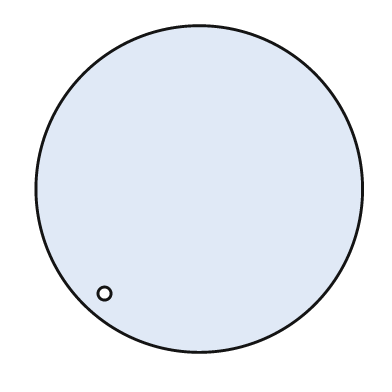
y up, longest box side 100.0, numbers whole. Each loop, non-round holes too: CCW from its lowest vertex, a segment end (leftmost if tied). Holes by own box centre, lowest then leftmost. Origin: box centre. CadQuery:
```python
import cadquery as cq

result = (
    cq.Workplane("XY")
    .moveTo(0.0, 0.0)
    .circle(50.0)
    .moveTo(-29.0, -32.0)
    .circle(2.0)
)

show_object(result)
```